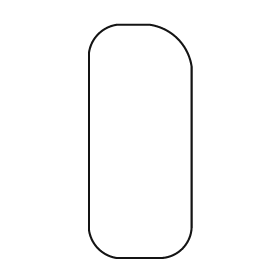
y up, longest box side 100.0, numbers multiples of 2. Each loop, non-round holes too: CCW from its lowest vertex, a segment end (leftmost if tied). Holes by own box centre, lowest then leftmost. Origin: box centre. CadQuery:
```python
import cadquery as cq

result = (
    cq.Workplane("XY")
    .moveTo(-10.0, -50.0)
    .lineTo(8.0, -50.0)
    .threePointArc((18.0, -46.0), (22.0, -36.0))
    .lineTo(22.0, 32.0)
    .threePointArc((16.0, 44.0), (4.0, 50.0))
    .lineTo(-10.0, 50.0)
    .threePointArc((-18.0, 46.0), (-22.0, 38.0))
    .lineTo(-22.0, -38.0)
    .threePointArc((-18.0, -46.0), (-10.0, -50.0))
    .close()
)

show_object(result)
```